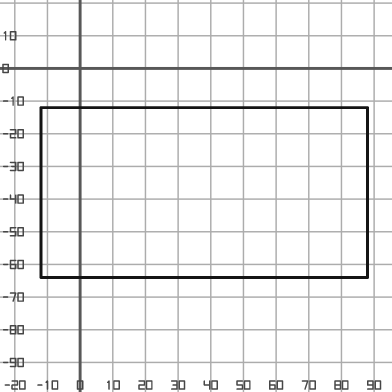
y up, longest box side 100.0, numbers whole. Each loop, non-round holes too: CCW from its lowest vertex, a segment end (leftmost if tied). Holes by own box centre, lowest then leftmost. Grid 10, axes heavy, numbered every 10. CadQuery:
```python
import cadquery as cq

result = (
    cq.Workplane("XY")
    .moveTo(-12.0, -64.0)
    .lineTo(88.0, -64.0)
    .lineTo(88.0, -12.0)
    .lineTo(-12.0, -12.0)
    .close()
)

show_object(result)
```